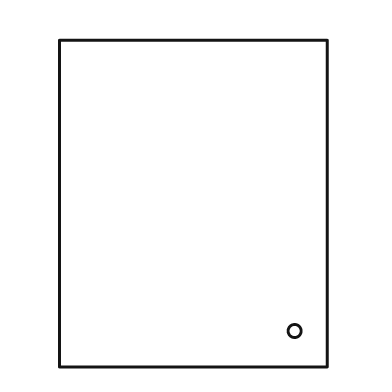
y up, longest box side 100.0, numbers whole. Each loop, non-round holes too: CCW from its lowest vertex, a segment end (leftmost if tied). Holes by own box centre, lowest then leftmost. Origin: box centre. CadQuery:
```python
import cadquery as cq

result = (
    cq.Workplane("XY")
    .moveTo(-41.0, -50.0)
    .lineTo(41.0, -50.0)
    .lineTo(41.0, 50.0)
    .lineTo(-41.0, 50.0)
    .close()
    .moveTo(31.0, -39.0)
    .circle(2.0)
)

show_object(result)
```